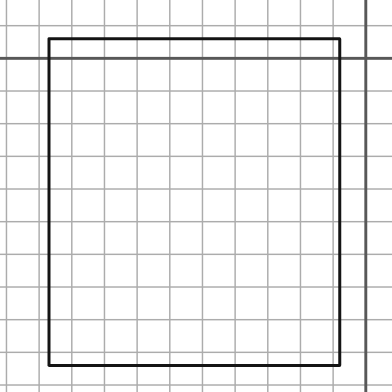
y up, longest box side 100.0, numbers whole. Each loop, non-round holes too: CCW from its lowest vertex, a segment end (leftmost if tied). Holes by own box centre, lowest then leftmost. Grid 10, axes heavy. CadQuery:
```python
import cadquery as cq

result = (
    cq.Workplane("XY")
    .moveTo(-97.0, -94.0)
    .lineTo(-8.0, -94.0)
    .lineTo(-8.0, 6.0)
    .lineTo(-97.0, 6.0)
    .close()
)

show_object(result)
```